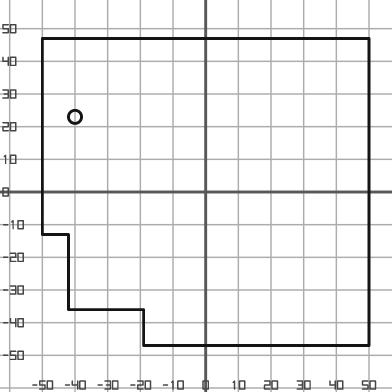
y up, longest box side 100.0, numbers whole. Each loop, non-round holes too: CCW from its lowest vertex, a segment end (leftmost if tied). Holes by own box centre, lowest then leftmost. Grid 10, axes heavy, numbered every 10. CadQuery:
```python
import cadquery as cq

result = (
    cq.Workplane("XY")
    .moveTo(-19.0, -47.0)
    .lineTo(50.0, -47.0)
    .lineTo(50.0, 47.0)
    .lineTo(-50.0, 47.0)
    .lineTo(-50.0, -13.0)
    .lineTo(-42.0, -13.0)
    .lineTo(-42.0, -36.0)
    .lineTo(-19.0, -36.0)
    .close()
    .moveTo(-40.0, 23.0)
    .circle(2.0)
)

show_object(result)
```